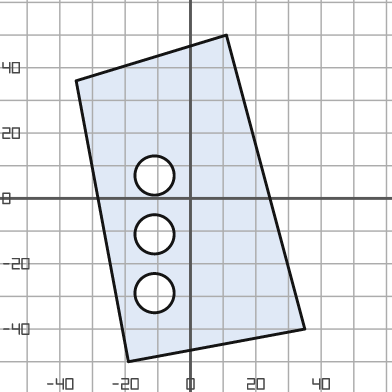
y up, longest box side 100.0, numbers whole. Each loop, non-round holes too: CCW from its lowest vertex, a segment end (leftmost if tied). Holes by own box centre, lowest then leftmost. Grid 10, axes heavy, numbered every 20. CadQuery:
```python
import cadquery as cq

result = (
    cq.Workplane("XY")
    .moveTo(-19.0, -50.0)
    .lineTo(35.0, -40.0)
    .lineTo(11.0, 50.0)
    .lineTo(-35.0, 36.0)
    .close()
    .moveTo(-11.0, -29.0)
    .circle(6.0)
    .moveTo(-11.0, -11.0)
    .circle(6.0)
    .moveTo(-11.0, 7.0)
    .circle(6.0)
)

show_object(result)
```